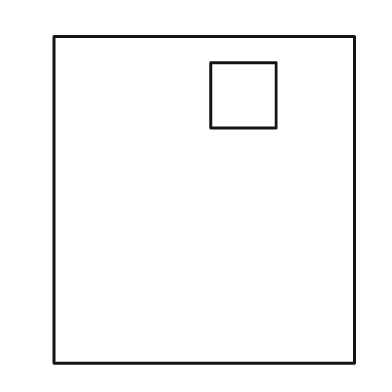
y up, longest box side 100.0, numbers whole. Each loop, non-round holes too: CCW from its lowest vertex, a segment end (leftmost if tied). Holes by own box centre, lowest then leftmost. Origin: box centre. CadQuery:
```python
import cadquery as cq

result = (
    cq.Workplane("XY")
    .moveTo(-46.0, -50.0)
    .lineTo(46.0, -50.0)
    .lineTo(46.0, 50.0)
    .lineTo(-46.0, 50.0)
    .close()
    .moveTo(2.0, 22.0)
    .lineTo(22.0, 22.0)
    .lineTo(22.0, 42.0)
    .lineTo(2.0, 42.0)
    .close()
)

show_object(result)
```